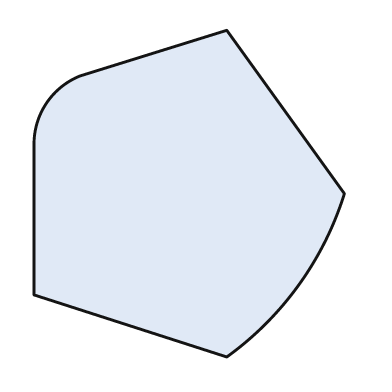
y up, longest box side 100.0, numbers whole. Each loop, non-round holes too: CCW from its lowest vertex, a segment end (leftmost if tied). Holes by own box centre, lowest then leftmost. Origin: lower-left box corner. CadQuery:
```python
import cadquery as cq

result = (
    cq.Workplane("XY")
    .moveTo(59.0, 0.0)
    .threePointArc((81.0, 22.0), (95.0, 50.0))
    .lineTo(59.0, 100.0)
    .lineTo(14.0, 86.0)
    .threePointArc((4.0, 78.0), (0.0, 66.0))
    .lineTo(0.0, 19.0)
    .close()
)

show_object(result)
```